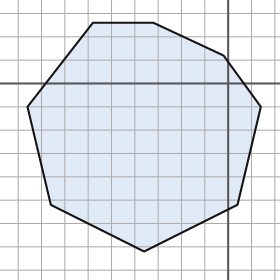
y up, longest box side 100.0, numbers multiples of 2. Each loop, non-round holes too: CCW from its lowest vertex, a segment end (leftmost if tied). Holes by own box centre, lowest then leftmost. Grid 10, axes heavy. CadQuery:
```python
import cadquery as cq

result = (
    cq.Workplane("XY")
    .moveTo(-36.0, -72.0)
    .lineTo(4.0, -52.0)
    .lineTo(14.0, -10.0)
    .lineTo(-2.0, 12.0)
    .lineTo(-32.0, 26.0)
    .lineTo(-58.0, 26.0)
    .lineTo(-86.0, -10.0)
    .lineTo(-76.0, -52.0)
    .close()
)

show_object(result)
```